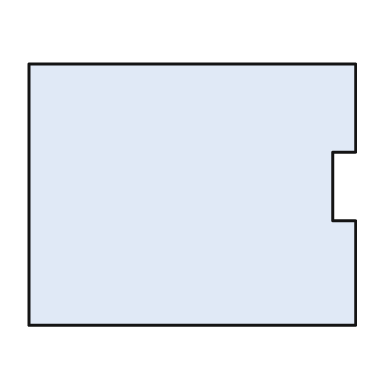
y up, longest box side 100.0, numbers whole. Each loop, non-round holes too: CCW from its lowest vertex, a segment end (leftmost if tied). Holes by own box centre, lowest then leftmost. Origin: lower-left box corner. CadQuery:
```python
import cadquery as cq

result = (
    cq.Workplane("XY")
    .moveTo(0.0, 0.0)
    .lineTo(100.0, 0.0)
    .lineTo(100.0, 32.0)
    .lineTo(93.0, 32.0)
    .lineTo(93.0, 53.0)
    .lineTo(100.0, 53.0)
    .lineTo(100.0, 80.0)
    .lineTo(0.0, 80.0)
    .close()
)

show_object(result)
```